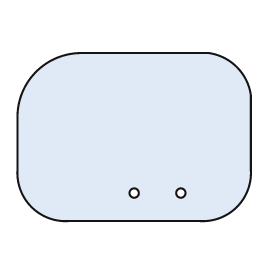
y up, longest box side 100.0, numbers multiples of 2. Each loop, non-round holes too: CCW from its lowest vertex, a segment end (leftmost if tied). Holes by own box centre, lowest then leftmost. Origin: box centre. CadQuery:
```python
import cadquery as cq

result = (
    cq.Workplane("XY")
    .moveTo(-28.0, -36.0)
    .lineTo(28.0, -36.0)
    .threePointArc((44.0, -30.0), (50.0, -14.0))
    .lineTo(50.0, 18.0)
    .threePointArc((44.0, 30.0), (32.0, 36.0))
    .lineTo(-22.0, 36.0)
    .threePointArc((-42.0, 28.0), (-50.0, 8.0))
    .lineTo(-50.0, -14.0)
    .threePointArc((-44.0, -30.0), (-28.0, -36.0))
    .close()
    .moveTo(0.0, -24.0)
    .circle(2.0)
    .moveTo(20.0, -24.0)
    .circle(2.0)
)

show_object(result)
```